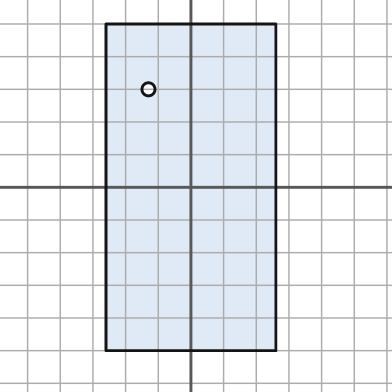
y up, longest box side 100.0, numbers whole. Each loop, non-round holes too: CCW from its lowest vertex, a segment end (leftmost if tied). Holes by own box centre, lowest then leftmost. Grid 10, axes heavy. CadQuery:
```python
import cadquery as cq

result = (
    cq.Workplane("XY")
    .moveTo(-26.0, -50.0)
    .lineTo(26.0, -50.0)
    .lineTo(26.0, 50.0)
    .lineTo(-26.0, 50.0)
    .close()
    .moveTo(-13.0, 30.0)
    .circle(2.0)
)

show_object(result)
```